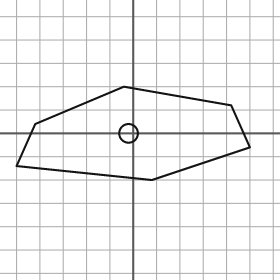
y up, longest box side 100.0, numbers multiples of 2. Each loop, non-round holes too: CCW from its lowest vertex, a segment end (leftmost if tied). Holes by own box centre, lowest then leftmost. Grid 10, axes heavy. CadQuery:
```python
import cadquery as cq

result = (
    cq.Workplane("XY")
    .moveTo(8.0, -20.0)
    .lineTo(50.0, -6.0)
    .lineTo(42.0, 12.0)
    .lineTo(-4.0, 20.0)
    .lineTo(-42.0, 4.0)
    .lineTo(-50.0, -14.0)
    .close()
    .moveTo(-2.0, 0.0)
    .circle(4.0)
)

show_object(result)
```